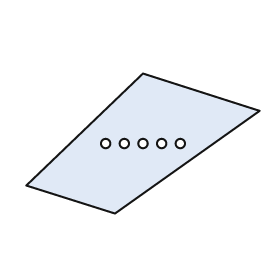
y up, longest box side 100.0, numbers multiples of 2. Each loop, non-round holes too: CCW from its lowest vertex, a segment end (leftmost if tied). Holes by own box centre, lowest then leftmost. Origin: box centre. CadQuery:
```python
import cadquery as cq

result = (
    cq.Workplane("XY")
    .moveTo(-12.0, -30.0)
    .lineTo(50.0, 14.0)
    .lineTo(0.0, 30.0)
    .lineTo(-50.0, -18.0)
    .close()
    .moveTo(-16.0, 0.0)
    .circle(2.0)
    .moveTo(-8.0, 0.0)
    .circle(2.0)
    .moveTo(0.0, 0.0)
    .circle(2.0)
    .moveTo(8.0, 0.0)
    .circle(2.0)
    .moveTo(16.0, 0.0)
    .circle(2.0)
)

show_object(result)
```